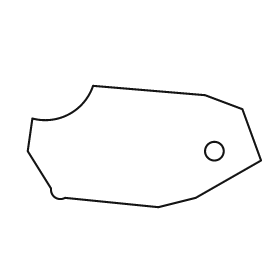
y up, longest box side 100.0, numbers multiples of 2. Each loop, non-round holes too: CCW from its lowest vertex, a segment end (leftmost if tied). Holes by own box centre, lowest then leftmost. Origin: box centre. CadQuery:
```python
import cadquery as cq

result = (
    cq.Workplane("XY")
    .moveTo(6.0, -26.0)
    .lineTo(22.0, -22.0)
    .lineTo(50.0, -6.0)
    .lineTo(42.0, 16.0)
    .lineTo(26.0, 22.0)
    .lineTo(-22.0, 26.0)
    .threePointArc((-32.0, 14.0), (-48.0, 12.0))
    .lineTo(-50.0, -2.0)
    .lineTo(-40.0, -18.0)
    .threePointArc((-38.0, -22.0), (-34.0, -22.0))
    .close()
    .moveTo(30.0, -2.0)
    .circle(4.0)
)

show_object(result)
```